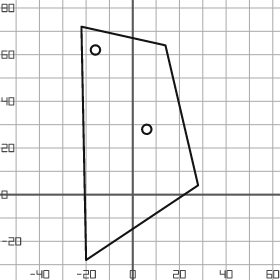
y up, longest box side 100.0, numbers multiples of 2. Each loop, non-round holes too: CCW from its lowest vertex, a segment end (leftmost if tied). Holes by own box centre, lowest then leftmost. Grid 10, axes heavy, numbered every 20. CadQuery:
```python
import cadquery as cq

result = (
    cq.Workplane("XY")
    .moveTo(-20.0, -28.0)
    .lineTo(28.0, 4.0)
    .lineTo(14.0, 64.0)
    .lineTo(-22.0, 72.0)
    .close()
    .moveTo(6.0, 28.0)
    .circle(2.0)
    .moveTo(-16.0, 62.0)
    .circle(2.0)
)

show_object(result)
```